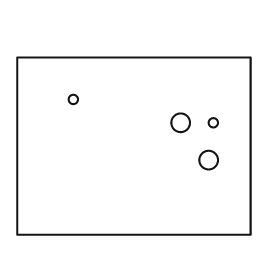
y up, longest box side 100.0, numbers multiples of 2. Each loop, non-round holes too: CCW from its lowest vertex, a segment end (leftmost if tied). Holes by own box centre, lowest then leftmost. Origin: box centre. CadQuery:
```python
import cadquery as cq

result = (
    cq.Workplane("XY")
    .moveTo(-50.0, -38.0)
    .lineTo(50.0, -38.0)
    .lineTo(50.0, 38.0)
    .lineTo(-50.0, 38.0)
    .close()
    .moveTo(32.0, -6.0)
    .circle(4.0)
    .moveTo(20.0, 10.0)
    .circle(4.0)
    .moveTo(34.0, 10.0)
    .circle(2.0)
    .moveTo(-26.0, 20.0)
    .circle(2.0)
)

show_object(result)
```